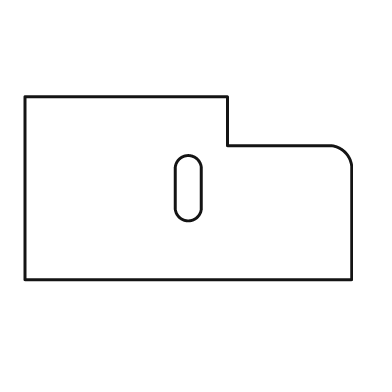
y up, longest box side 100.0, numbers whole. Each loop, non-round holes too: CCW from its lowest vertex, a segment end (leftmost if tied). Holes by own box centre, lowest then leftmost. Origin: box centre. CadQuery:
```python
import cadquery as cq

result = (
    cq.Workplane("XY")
    .moveTo(-50.0, -28.0)
    .lineTo(50.0, -28.0)
    .lineTo(50.0, 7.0)
    .threePointArc((48.0, 11.0), (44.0, 13.0))
    .lineTo(12.0, 13.0)
    .lineTo(12.0, 28.0)
    .lineTo(-50.0, 28.0)
    .close()
    .moveTo(-4.0, -6.0)
    .threePointArc((0.0, -10.0), (4.0, -6.0))
    .lineTo(4.0, 6.0)
    .threePointArc((0.0, 10.0), (-4.0, 6.0))
    .close()
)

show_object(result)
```